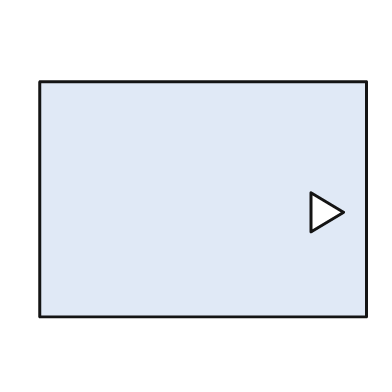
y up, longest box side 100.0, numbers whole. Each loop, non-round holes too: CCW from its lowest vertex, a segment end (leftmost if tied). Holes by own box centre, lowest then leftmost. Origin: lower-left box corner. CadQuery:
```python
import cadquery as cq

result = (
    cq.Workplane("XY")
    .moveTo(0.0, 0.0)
    .lineTo(100.0, 0.0)
    .lineTo(100.0, 72.0)
    .lineTo(0.0, 72.0)
    .close()
    .moveTo(83.0, 26.0)
    .lineTo(93.0, 32.0)
    .lineTo(83.0, 38.0)
    .close()
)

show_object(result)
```